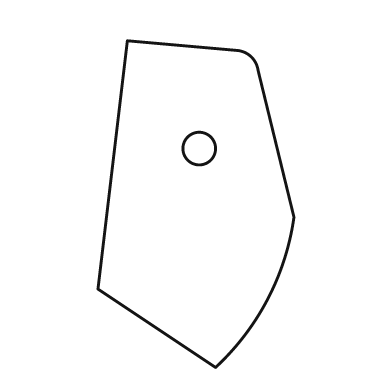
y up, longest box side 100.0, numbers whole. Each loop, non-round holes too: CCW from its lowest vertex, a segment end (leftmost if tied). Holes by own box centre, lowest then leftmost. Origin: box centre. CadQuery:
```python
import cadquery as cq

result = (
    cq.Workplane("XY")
    .moveTo(6.0, -50.0)
    .threePointArc((22.0, -29.0), (30.0, -4.0))
    .lineTo(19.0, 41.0)
    .threePointArc((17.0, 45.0), (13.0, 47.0))
    .lineTo(-21.0, 50.0)
    .lineTo(-30.0, -26.0)
    .close()
    .moveTo(1.0, 17.0)
    .circle(5.0)
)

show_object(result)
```